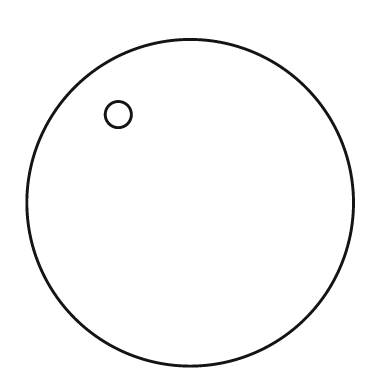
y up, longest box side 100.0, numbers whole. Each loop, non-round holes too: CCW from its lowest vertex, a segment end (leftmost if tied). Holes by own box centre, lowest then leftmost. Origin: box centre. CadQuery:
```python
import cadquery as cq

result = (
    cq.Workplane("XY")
    .moveTo(0.0, 0.0)
    .circle(50.0)
    .moveTo(-22.0, 27.0)
    .circle(4.0)
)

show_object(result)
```